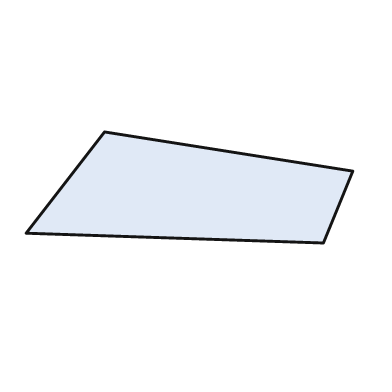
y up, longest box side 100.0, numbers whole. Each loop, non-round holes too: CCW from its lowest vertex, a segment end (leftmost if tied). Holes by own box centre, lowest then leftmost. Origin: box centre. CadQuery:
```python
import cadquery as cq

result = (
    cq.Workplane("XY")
    .moveTo(41.0, -17.0)
    .lineTo(50.0, 5.0)
    .lineTo(-26.0, 17.0)
    .lineTo(-50.0, -14.0)
    .close()
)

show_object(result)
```